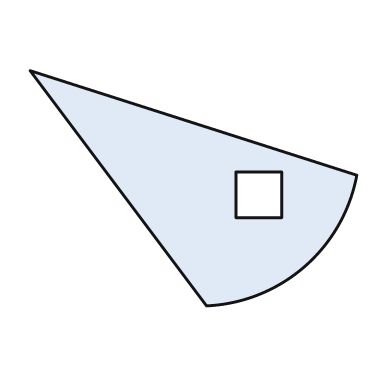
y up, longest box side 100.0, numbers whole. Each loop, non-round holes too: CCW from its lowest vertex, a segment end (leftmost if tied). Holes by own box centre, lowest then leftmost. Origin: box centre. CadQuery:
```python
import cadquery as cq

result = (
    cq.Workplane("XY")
    .moveTo(4.0, -36.0)
    .threePointArc((34.0, -24.0), (50.0, 4.0))
    .lineTo(-50.0, 36.0)
    .close()
    .moveTo(13.0, -9.0)
    .lineTo(27.0, -9.0)
    .lineTo(27.0, 5.0)
    .lineTo(13.0, 5.0)
    .close()
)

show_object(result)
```